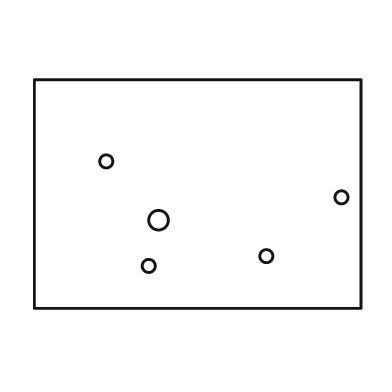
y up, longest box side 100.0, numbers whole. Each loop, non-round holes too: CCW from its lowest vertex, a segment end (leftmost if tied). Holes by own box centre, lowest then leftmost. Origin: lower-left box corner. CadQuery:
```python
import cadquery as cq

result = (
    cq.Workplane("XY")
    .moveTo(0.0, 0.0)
    .lineTo(100.0, 0.0)
    .lineTo(100.0, 70.0)
    .lineTo(0.0, 70.0)
    .close()
    .moveTo(35.0, 13.0)
    .circle(2.0)
    .moveTo(71.0, 16.0)
    .circle(2.0)
    .moveTo(38.0, 27.0)
    .circle(3.0)
    .moveTo(94.0, 34.0)
    .circle(2.0)
    .moveTo(22.0, 45.0)
    .circle(2.0)
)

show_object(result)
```